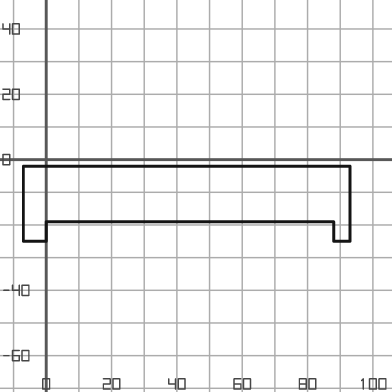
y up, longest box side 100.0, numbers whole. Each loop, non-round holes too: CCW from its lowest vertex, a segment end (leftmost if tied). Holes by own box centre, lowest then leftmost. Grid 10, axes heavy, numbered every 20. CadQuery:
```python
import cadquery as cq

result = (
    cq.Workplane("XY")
    .moveTo(-7.0, -25.0)
    .lineTo(0.0, -25.0)
    .lineTo(0.0, -19.0)
    .lineTo(88.0, -19.0)
    .lineTo(88.0, -25.0)
    .lineTo(93.0, -25.0)
    .lineTo(93.0, -2.0)
    .lineTo(-7.0, -2.0)
    .close()
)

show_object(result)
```